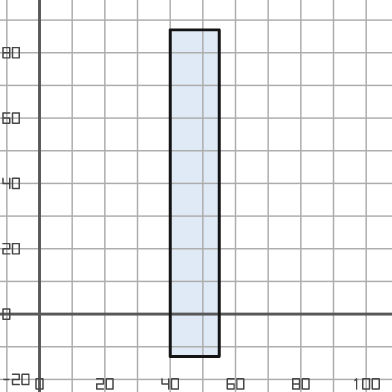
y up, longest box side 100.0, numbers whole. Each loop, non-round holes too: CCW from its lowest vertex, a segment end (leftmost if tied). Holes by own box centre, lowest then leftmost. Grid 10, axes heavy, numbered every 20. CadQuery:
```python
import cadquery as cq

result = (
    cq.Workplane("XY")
    .moveTo(40.0, -13.0)
    .lineTo(55.0, -13.0)
    .lineTo(55.0, 87.0)
    .lineTo(40.0, 87.0)
    .close()
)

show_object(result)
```